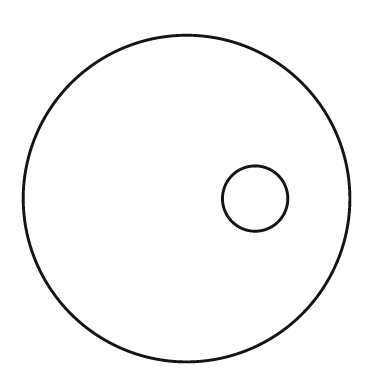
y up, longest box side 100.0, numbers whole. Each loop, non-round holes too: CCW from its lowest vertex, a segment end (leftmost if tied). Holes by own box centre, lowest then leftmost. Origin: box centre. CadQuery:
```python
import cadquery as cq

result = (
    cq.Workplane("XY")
    .moveTo(0.0, 0.0)
    .circle(50.0)
    .moveTo(21.0, 0.0)
    .circle(10.0)
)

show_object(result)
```